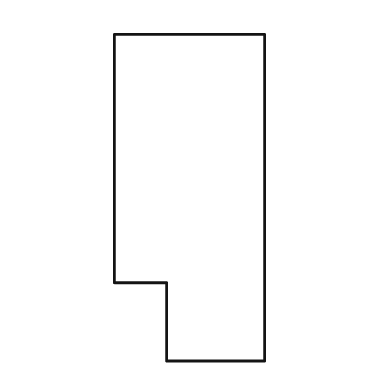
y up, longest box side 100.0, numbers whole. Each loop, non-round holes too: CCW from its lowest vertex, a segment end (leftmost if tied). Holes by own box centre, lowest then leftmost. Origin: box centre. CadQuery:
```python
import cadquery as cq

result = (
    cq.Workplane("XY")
    .moveTo(-7.0, -50.0)
    .lineTo(23.0, -50.0)
    .lineTo(23.0, 50.0)
    .lineTo(-23.0, 50.0)
    .lineTo(-23.0, -26.0)
    .lineTo(-7.0, -26.0)
    .close()
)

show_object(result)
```